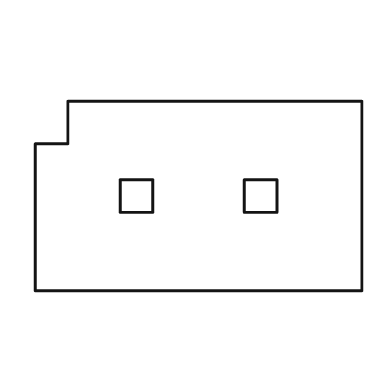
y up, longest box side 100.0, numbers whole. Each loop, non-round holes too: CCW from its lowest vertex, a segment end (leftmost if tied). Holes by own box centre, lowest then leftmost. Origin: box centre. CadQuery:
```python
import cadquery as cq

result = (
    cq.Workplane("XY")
    .moveTo(-50.0, -29.0)
    .lineTo(50.0, -29.0)
    .lineTo(50.0, 29.0)
    .lineTo(-40.0, 29.0)
    .lineTo(-40.0, 16.0)
    .lineTo(-50.0, 16.0)
    .close()
    .moveTo(-24.0, -5.0)
    .lineTo(-14.0, -5.0)
    .lineTo(-14.0, 5.0)
    .lineTo(-24.0, 5.0)
    .close()
    .moveTo(14.0, -5.0)
    .lineTo(24.0, -5.0)
    .lineTo(24.0, 5.0)
    .lineTo(14.0, 5.0)
    .close()
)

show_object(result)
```